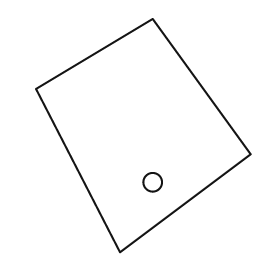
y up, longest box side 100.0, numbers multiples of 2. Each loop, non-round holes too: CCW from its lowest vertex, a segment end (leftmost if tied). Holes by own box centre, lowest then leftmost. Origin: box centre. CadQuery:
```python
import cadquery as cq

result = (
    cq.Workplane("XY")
    .moveTo(-10.0, -50.0)
    .lineTo(46.0, -8.0)
    .lineTo(4.0, 50.0)
    .lineTo(-46.0, 20.0)
    .close()
    .moveTo(4.0, -20.0)
    .circle(4.0)
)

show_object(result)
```